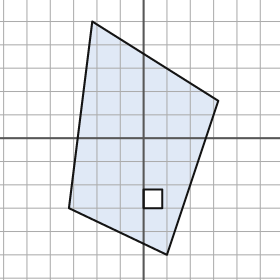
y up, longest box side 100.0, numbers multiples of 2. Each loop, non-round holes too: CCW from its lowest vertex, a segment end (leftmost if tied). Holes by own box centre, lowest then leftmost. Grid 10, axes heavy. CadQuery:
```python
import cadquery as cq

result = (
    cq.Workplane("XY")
    .moveTo(10.0, -50.0)
    .lineTo(32.0, 16.0)
    .lineTo(-22.0, 50.0)
    .lineTo(-32.0, -30.0)
    .close()
    .moveTo(0.0, -30.0)
    .lineTo(8.0, -30.0)
    .lineTo(8.0, -22.0)
    .lineTo(0.0, -22.0)
    .close()
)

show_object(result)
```